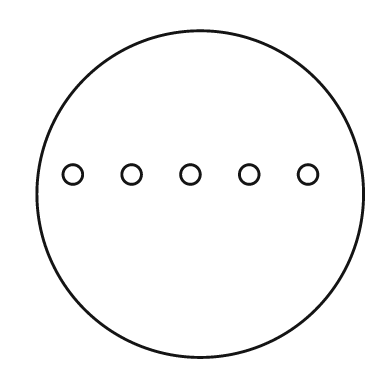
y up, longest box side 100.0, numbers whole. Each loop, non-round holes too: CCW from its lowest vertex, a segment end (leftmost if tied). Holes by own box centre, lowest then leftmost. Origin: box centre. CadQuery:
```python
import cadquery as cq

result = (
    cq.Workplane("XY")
    .moveTo(0.0, 0.0)
    .circle(50.0)
    .moveTo(-39.0, 6.0)
    .circle(3.0)
    .moveTo(-21.0, 6.0)
    .circle(3.0)
    .moveTo(-3.0, 6.0)
    .circle(3.0)
    .moveTo(15.0, 6.0)
    .circle(3.0)
    .moveTo(33.0, 6.0)
    .circle(3.0)
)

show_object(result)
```